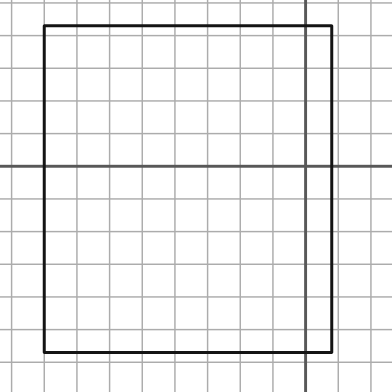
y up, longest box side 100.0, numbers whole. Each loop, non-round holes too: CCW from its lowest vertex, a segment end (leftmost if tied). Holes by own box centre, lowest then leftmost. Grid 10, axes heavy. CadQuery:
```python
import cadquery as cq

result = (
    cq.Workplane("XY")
    .moveTo(-80.0, -57.0)
    .lineTo(8.0, -57.0)
    .lineTo(8.0, 43.0)
    .lineTo(-80.0, 43.0)
    .close()
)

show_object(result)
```